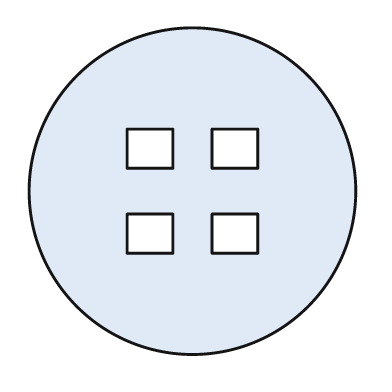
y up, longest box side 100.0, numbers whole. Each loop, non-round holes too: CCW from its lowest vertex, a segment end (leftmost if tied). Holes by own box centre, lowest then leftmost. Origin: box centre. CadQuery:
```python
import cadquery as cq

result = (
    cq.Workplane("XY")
    .moveTo(0.0, 0.0)
    .circle(50.0)
    .moveTo(-20.0, -19.0)
    .lineTo(-6.0, -19.0)
    .lineTo(-6.0, -7.0)
    .lineTo(-20.0, -7.0)
    .close()
    .moveTo(6.0, -19.0)
    .lineTo(20.0, -19.0)
    .lineTo(20.0, -7.0)
    .lineTo(6.0, -7.0)
    .close()
    .moveTo(-20.0, 7.0)
    .lineTo(-6.0, 7.0)
    .lineTo(-6.0, 19.0)
    .lineTo(-20.0, 19.0)
    .close()
    .moveTo(6.0, 7.0)
    .lineTo(20.0, 7.0)
    .lineTo(20.0, 19.0)
    .lineTo(6.0, 19.0)
    .close()
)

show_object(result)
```